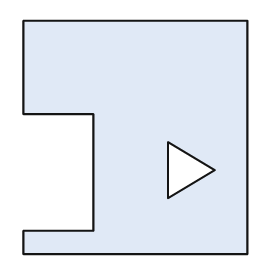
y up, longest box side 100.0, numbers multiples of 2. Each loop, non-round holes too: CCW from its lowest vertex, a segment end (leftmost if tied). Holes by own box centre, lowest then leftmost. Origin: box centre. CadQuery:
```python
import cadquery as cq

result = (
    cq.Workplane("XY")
    .moveTo(-48.0, -50.0)
    .lineTo(48.0, -50.0)
    .lineTo(48.0, 50.0)
    .lineTo(-48.0, 50.0)
    .lineTo(-48.0, 10.0)
    .lineTo(-18.0, 10.0)
    .lineTo(-18.0, -40.0)
    .lineTo(-48.0, -40.0)
    .close()
    .moveTo(14.0, -26.0)
    .lineTo(34.0, -14.0)
    .lineTo(14.0, -2.0)
    .close()
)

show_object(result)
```